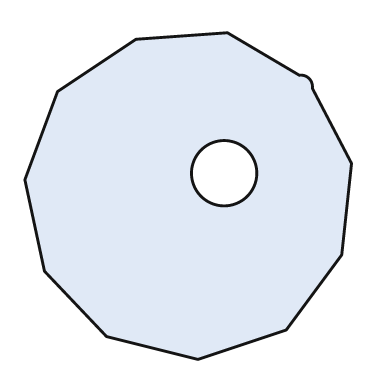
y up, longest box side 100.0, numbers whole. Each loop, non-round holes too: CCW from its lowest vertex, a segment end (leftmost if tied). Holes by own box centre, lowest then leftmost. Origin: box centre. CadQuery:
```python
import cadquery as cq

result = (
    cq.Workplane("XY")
    .moveTo(3.0, -50.0)
    .lineTo(30.0, -41.0)
    .lineTo(47.0, -18.0)
    .lineTo(50.0, 10.0)
    .lineTo(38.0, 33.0)
    .threePointArc((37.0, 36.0), (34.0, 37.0))
    .lineTo(12.0, 50.0)
    .lineTo(-16.0, 48.0)
    .lineTo(-40.0, 32.0)
    .lineTo(-50.0, 5.0)
    .lineTo(-44.0, -23.0)
    .lineTo(-25.0, -43.0)
    .close()
    .moveTo(11.0, 7.0)
    .circle(10.0)
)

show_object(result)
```